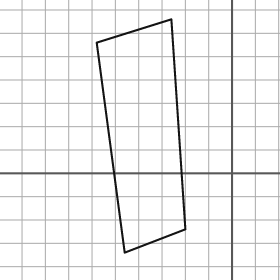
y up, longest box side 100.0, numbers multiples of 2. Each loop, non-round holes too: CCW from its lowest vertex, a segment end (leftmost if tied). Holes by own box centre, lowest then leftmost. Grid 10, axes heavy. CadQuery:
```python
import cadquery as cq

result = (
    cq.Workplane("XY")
    .moveTo(-46.0, -34.0)
    .lineTo(-20.0, -24.0)
    .lineTo(-26.0, 66.0)
    .lineTo(-58.0, 56.0)
    .close()
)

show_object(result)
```